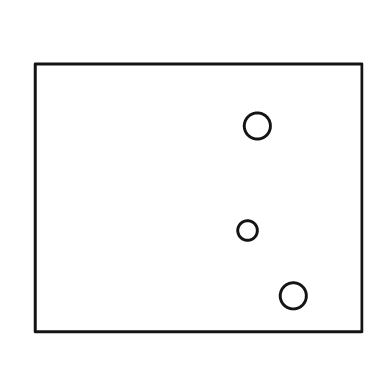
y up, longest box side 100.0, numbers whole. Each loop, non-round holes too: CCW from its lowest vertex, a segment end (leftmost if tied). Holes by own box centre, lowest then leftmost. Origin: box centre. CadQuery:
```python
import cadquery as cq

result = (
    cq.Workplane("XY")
    .moveTo(-50.0, -41.0)
    .lineTo(50.0, -41.0)
    .lineTo(50.0, 41.0)
    .lineTo(-50.0, 41.0)
    .close()
    .moveTo(29.0, -30.0)
    .circle(4.0)
    .moveTo(15.0, -10.0)
    .circle(3.0)
    .moveTo(18.0, 22.0)
    .circle(4.0)
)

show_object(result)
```